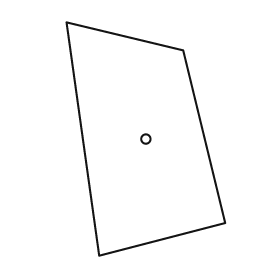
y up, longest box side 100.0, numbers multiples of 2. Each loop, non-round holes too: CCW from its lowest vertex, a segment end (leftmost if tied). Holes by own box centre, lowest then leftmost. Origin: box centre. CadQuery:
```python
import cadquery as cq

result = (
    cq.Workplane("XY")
    .moveTo(-20.0, -50.0)
    .lineTo(34.0, -36.0)
    .lineTo(16.0, 38.0)
    .lineTo(-34.0, 50.0)
    .close()
    .moveTo(0.0, 0.0)
    .circle(2.0)
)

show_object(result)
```